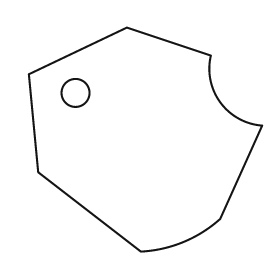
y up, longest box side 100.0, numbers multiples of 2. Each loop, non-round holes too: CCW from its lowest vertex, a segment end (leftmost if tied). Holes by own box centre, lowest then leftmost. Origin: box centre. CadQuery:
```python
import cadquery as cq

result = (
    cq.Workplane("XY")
    .moveTo(-2.0, -48.0)
    .threePointArc((16.0, -44.0), (32.0, -34.0))
    .lineTo(50.0, 6.0)
    .threePointArc((32.0, 16.0), (28.0, 36.0))
    .lineTo(-8.0, 48.0)
    .lineTo(-50.0, 28.0)
    .lineTo(-46.0, -14.0)
    .close()
    .moveTo(-30.0, 20.0)
    .circle(6.0)
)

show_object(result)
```